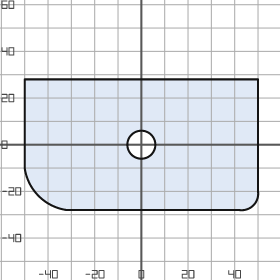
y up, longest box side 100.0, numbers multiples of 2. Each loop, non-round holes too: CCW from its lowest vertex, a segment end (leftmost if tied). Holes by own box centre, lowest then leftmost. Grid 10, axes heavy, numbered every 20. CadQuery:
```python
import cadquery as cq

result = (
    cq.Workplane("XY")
    .moveTo(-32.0, -28.0)
    .lineTo(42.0, -28.0)
    .threePointArc((48.0, -26.0), (50.0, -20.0))
    .lineTo(50.0, 28.0)
    .lineTo(-50.0, 28.0)
    .lineTo(-50.0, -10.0)
    .threePointArc((-44.0, -22.0), (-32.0, -28.0))
    .close()
    .moveTo(0.0, 0.0)
    .circle(6.0)
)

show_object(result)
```